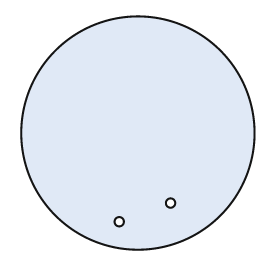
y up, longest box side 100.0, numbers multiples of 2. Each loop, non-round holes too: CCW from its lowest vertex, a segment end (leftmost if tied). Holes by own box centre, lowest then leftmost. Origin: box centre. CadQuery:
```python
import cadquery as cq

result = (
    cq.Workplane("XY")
    .moveTo(0.0, 0.0)
    .circle(50.0)
    .moveTo(-8.0, -38.0)
    .circle(2.0)
    .moveTo(14.0, -30.0)
    .circle(2.0)
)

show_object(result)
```